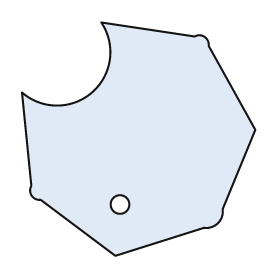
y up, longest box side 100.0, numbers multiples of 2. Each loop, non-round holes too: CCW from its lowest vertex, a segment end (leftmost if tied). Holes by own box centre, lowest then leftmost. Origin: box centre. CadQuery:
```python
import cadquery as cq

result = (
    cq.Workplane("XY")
    .moveTo(-10.0, -50.0)
    .lineTo(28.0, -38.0)
    .threePointArc((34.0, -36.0), (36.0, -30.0))
    .lineTo(50.0, 4.0)
    .lineTo(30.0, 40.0)
    .threePointArc((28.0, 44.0), (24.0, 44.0))
    .lineTo(-16.0, 50.0)
    .threePointArc((-20.0, 20.0), (-50.0, 20.0))
    .lineTo(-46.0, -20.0)
    .threePointArc((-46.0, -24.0), (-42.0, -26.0))
    .close()
    .moveTo(-8.0, -28.0)
    .circle(4.0)
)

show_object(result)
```